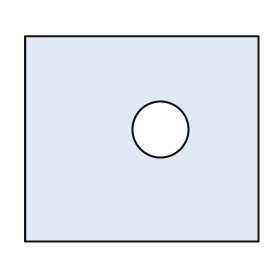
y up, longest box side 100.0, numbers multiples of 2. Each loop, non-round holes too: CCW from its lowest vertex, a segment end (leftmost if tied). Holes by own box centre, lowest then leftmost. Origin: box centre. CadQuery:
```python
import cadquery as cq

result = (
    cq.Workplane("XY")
    .moveTo(-50.0, -44.0)
    .lineTo(50.0, -44.0)
    .lineTo(50.0, 44.0)
    .lineTo(-50.0, 44.0)
    .close()
    .moveTo(8.0, 4.0)
    .circle(12.0)
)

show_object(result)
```